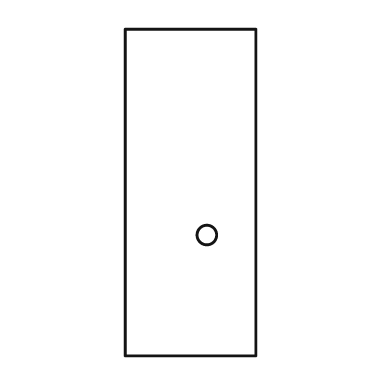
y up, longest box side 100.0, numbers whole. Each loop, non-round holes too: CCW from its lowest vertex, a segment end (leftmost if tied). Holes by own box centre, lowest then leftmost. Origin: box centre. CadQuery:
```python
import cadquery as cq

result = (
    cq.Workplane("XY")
    .moveTo(-20.0, -50.0)
    .lineTo(20.0, -50.0)
    .lineTo(20.0, 50.0)
    .lineTo(-20.0, 50.0)
    .close()
    .moveTo(5.0, -13.0)
    .circle(3.0)
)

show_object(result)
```